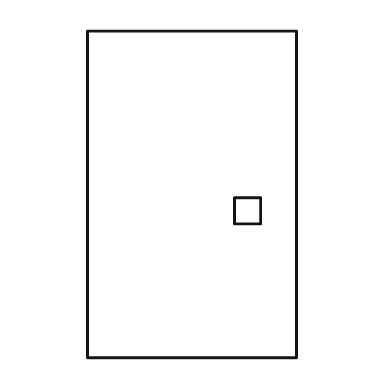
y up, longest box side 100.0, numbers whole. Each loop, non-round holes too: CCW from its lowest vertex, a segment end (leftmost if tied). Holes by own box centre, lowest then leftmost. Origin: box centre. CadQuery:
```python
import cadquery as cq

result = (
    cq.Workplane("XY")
    .moveTo(-32.0, -50.0)
    .lineTo(32.0, -50.0)
    .lineTo(32.0, 50.0)
    .lineTo(-32.0, 50.0)
    .close()
    .moveTo(13.0, -9.0)
    .lineTo(21.0, -9.0)
    .lineTo(21.0, -1.0)
    .lineTo(13.0, -1.0)
    .close()
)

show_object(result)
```